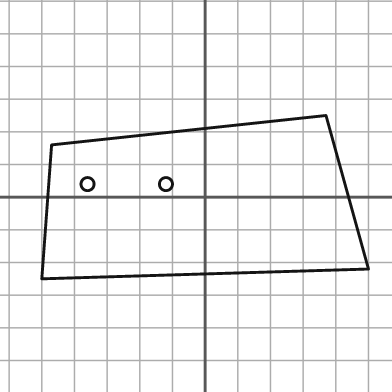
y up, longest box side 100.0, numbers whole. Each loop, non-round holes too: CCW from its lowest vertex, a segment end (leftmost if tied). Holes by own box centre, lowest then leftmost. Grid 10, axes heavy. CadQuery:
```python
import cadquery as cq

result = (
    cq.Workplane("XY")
    .moveTo(-50.0, -25.0)
    .lineTo(50.0, -22.0)
    .lineTo(37.0, 25.0)
    .lineTo(-47.0, 16.0)
    .close()
    .moveTo(-36.0, 4.0)
    .circle(2.0)
    .moveTo(-12.0, 4.0)
    .circle(2.0)
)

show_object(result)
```